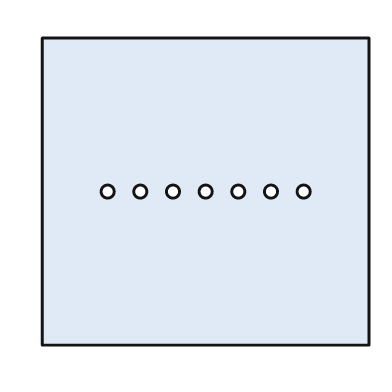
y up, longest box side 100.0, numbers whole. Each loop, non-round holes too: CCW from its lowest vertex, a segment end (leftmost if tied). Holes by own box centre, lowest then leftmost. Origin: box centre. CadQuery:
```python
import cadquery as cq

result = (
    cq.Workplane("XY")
    .moveTo(-50.0, -47.0)
    .lineTo(50.0, -47.0)
    .lineTo(50.0, 47.0)
    .lineTo(-50.0, 47.0)
    .close()
    .moveTo(-30.0, 0.0)
    .circle(2.0)
    .moveTo(-20.0, 0.0)
    .circle(2.0)
    .moveTo(-10.0, 0.0)
    .circle(2.0)
    .moveTo(0.0, 0.0)
    .circle(2.0)
    .moveTo(10.0, 0.0)
    .circle(2.0)
    .moveTo(20.0, 0.0)
    .circle(2.0)
    .moveTo(30.0, 0.0)
    .circle(2.0)
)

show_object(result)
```